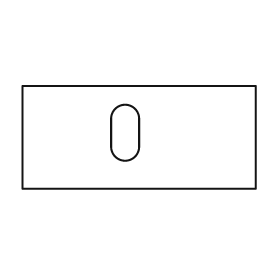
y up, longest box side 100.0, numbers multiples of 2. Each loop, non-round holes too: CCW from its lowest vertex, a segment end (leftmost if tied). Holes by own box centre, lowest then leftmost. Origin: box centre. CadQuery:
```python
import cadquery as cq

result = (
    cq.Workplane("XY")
    .moveTo(-50.0, -22.0)
    .lineTo(50.0, -22.0)
    .lineTo(50.0, 22.0)
    .lineTo(-50.0, 22.0)
    .close()
    .moveTo(-12.0, -4.0)
    .threePointArc((-6.0, -10.0), (0.0, -4.0))
    .lineTo(0.0, 8.0)
    .threePointArc((-6.0, 14.0), (-12.0, 8.0))
    .close()
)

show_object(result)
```